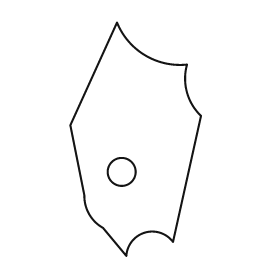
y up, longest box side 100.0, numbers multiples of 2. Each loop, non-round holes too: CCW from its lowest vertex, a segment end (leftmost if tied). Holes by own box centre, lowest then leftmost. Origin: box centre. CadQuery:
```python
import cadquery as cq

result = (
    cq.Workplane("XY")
    .moveTo(-4.0, -50.0)
    .threePointArc((4.0, -40.0), (16.0, -44.0))
    .lineTo(28.0, 10.0)
    .threePointArc((22.0, 20.0), (22.0, 32.0))
    .threePointArc((4.0, 36.0), (-8.0, 50.0))
    .lineTo(-28.0, 6.0)
    .lineTo(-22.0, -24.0)
    .threePointArc((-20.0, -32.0), (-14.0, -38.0))
    .close()
    .moveTo(-6.0, -14.0)
    .circle(6.0)
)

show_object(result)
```